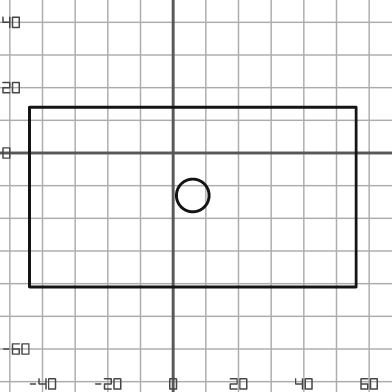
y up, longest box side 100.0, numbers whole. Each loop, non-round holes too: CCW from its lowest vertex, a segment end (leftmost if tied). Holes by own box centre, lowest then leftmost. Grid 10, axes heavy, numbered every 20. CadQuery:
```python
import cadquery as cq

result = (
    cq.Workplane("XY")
    .moveTo(-44.0, -41.0)
    .lineTo(56.0, -41.0)
    .lineTo(56.0, 14.0)
    .lineTo(-44.0, 14.0)
    .close()
    .moveTo(6.0, -13.0)
    .circle(5.0)
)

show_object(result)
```